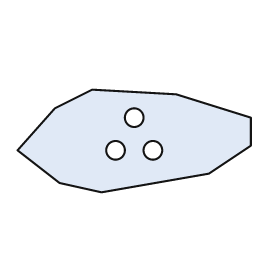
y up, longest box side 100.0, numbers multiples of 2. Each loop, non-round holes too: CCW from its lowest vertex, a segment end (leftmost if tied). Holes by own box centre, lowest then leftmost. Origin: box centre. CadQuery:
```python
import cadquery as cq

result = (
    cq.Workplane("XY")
    .moveTo(-14.0, -22.0)
    .lineTo(32.0, -14.0)
    .lineTo(50.0, -2.0)
    .lineTo(50.0, 10.0)
    .lineTo(18.0, 20.0)
    .lineTo(-18.0, 22.0)
    .lineTo(-34.0, 14.0)
    .lineTo(-50.0, -4.0)
    .lineTo(-32.0, -18.0)
    .close()
    .moveTo(-8.0, -4.0)
    .circle(4.0)
    .moveTo(8.0, -4.0)
    .circle(4.0)
    .moveTo(0.0, 10.0)
    .circle(4.0)
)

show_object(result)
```